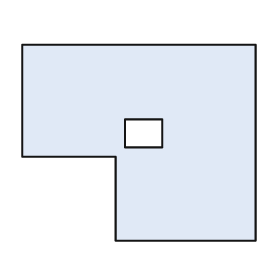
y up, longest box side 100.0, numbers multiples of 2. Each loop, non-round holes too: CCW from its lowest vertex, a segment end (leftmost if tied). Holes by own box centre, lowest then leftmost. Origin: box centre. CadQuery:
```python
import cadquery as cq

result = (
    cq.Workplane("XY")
    .moveTo(-10.0, -42.0)
    .lineTo(50.0, -42.0)
    .lineTo(50.0, 42.0)
    .lineTo(-50.0, 42.0)
    .lineTo(-50.0, -6.0)
    .lineTo(-10.0, -6.0)
    .close()
    .moveTo(-6.0, -2.0)
    .lineTo(10.0, -2.0)
    .lineTo(10.0, 10.0)
    .lineTo(-6.0, 10.0)
    .close()
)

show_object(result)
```